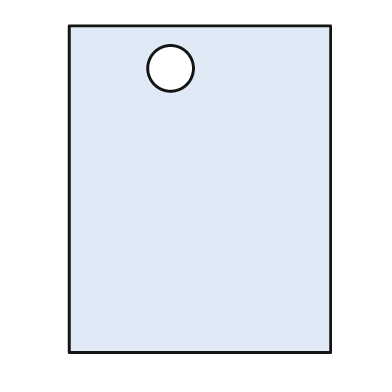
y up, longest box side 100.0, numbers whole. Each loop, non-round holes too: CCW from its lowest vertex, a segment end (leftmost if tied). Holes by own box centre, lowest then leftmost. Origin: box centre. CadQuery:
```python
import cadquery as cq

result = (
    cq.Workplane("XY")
    .moveTo(-40.0, -50.0)
    .lineTo(40.0, -50.0)
    .lineTo(40.0, 50.0)
    .lineTo(-40.0, 50.0)
    .close()
    .moveTo(-9.0, 37.0)
    .circle(7.0)
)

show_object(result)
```